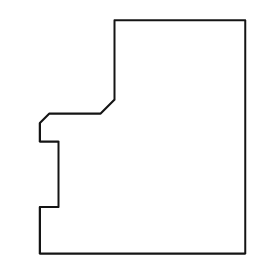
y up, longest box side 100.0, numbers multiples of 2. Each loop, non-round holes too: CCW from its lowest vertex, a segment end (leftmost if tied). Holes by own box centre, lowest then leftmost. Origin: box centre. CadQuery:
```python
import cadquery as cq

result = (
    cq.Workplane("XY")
    .moveTo(-44.0, -50.0)
    .lineTo(44.0, -50.0)
    .lineTo(44.0, 50.0)
    .lineTo(-12.0, 50.0)
    .lineTo(-12.0, 16.0)
    .lineTo(-18.0, 10.0)
    .lineTo(-40.0, 10.0)
    .lineTo(-44.0, 6.0)
    .lineTo(-44.0, -2.0)
    .lineTo(-36.0, -2.0)
    .lineTo(-36.0, -30.0)
    .lineTo(-44.0, -30.0)
    .close()
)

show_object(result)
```